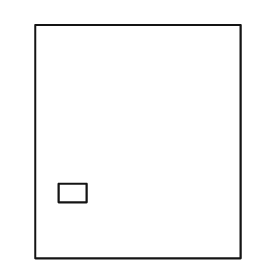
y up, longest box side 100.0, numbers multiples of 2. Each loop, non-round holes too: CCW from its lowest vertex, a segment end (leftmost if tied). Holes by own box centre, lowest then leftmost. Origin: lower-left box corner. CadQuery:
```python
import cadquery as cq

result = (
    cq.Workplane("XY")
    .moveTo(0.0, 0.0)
    .lineTo(88.0, 0.0)
    .lineTo(88.0, 100.0)
    .lineTo(0.0, 100.0)
    .close()
    .moveTo(10.0, 24.0)
    .lineTo(22.0, 24.0)
    .lineTo(22.0, 32.0)
    .lineTo(10.0, 32.0)
    .close()
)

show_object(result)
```